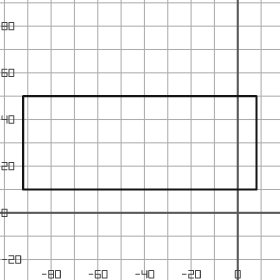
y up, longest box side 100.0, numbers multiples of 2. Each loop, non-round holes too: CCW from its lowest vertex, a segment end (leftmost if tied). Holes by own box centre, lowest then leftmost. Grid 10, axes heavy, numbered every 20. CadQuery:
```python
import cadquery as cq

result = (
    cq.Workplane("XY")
    .moveTo(-92.0, 10.0)
    .lineTo(8.0, 10.0)
    .lineTo(8.0, 50.0)
    .lineTo(-92.0, 50.0)
    .close()
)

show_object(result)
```